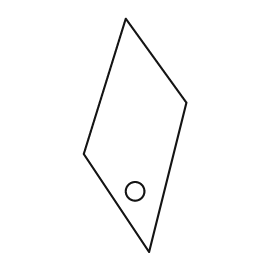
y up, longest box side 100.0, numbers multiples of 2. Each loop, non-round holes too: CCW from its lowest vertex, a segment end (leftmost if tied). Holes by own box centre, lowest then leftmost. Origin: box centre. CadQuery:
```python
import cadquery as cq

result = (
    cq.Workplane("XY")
    .moveTo(6.0, -50.0)
    .lineTo(22.0, 14.0)
    .lineTo(-4.0, 50.0)
    .lineTo(-22.0, -8.0)
    .close()
    .moveTo(0.0, -24.0)
    .circle(4.0)
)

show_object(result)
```